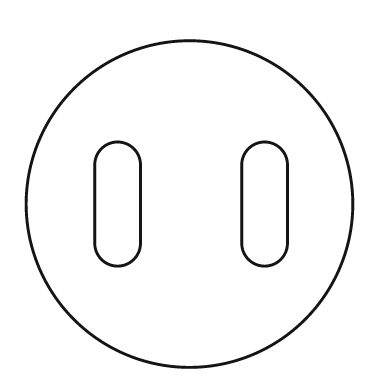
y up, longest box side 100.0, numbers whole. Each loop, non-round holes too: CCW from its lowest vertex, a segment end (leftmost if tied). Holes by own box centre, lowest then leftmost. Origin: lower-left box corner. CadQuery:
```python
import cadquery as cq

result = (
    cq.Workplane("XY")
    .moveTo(50.0, 50.0)
    .circle(50.0)
    .moveTo(21.0, 38.0)
    .threePointArc((28.0, 31.0), (35.0, 38.0))
    .lineTo(35.0, 62.0)
    .threePointArc((28.0, 69.0), (21.0, 62.0))
    .close()
    .moveTo(66.0, 38.0)
    .threePointArc((73.0, 31.0), (80.0, 38.0))
    .lineTo(80.0, 62.0)
    .threePointArc((73.0, 69.0), (66.0, 62.0))
    .close()
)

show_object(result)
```